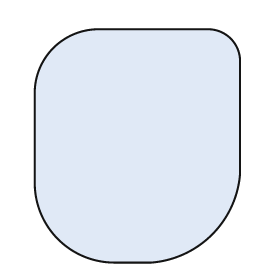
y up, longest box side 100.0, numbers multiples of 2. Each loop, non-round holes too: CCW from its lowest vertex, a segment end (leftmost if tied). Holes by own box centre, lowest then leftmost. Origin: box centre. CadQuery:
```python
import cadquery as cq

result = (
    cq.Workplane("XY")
    .moveTo(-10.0, -50.0)
    .lineTo(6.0, -50.0)
    .threePointArc((32.0, -38.0), (44.0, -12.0))
    .lineTo(44.0, 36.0)
    .threePointArc((40.0, 46.0), (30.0, 50.0))
    .lineTo(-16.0, 50.0)
    .threePointArc((-36.0, 42.0), (-44.0, 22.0))
    .lineTo(-44.0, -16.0)
    .threePointArc((-34.0, -40.0), (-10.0, -50.0))
    .close()
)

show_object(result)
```